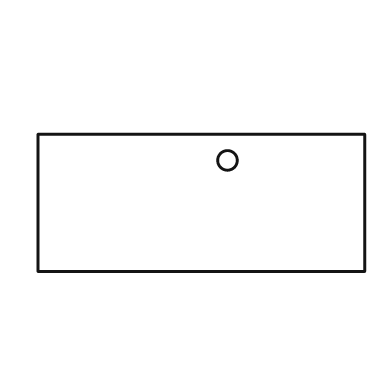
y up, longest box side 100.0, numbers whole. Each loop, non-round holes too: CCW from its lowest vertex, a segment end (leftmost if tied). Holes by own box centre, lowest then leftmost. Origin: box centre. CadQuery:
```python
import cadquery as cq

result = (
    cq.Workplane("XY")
    .moveTo(-50.0, -21.0)
    .lineTo(50.0, -21.0)
    .lineTo(50.0, 21.0)
    .lineTo(-50.0, 21.0)
    .close()
    .moveTo(8.0, 13.0)
    .circle(3.0)
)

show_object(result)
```